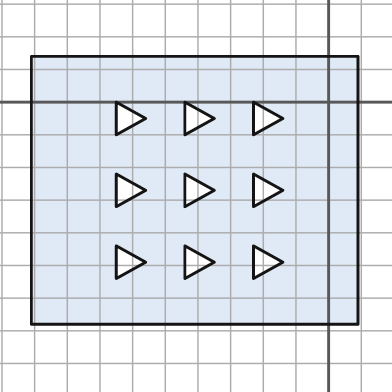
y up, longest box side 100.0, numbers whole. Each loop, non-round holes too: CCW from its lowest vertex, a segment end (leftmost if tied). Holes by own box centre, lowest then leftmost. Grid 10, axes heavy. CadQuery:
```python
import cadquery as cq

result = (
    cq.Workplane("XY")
    .moveTo(-91.0, -68.0)
    .lineTo(9.0, -68.0)
    .lineTo(9.0, 14.0)
    .lineTo(-91.0, 14.0)
    .close()
    .moveTo(-65.0, -54.0)
    .lineTo(-56.0, -49.0)
    .lineTo(-65.0, -44.0)
    .close()
    .moveTo(-44.0, -54.0)
    .lineTo(-35.0, -49.0)
    .lineTo(-44.0, -44.0)
    .close()
    .moveTo(-23.0, -54.0)
    .lineTo(-14.0, -49.0)
    .lineTo(-23.0, -44.0)
    .close()
    .moveTo(-65.0, -32.0)
    .lineTo(-56.0, -27.0)
    .lineTo(-65.0, -22.0)
    .close()
    .moveTo(-44.0, -32.0)
    .lineTo(-35.0, -27.0)
    .lineTo(-44.0, -22.0)
    .close()
    .moveTo(-23.0, -32.0)
    .lineTo(-14.0, -27.0)
    .lineTo(-23.0, -22.0)
    .close()
    .moveTo(-65.0, -10.0)
    .lineTo(-56.0, -5.0)
    .lineTo(-65.0, 0.0)
    .close()
    .moveTo(-44.0, -10.0)
    .lineTo(-35.0, -5.0)
    .lineTo(-44.0, 0.0)
    .close()
    .moveTo(-23.0, -10.0)
    .lineTo(-14.0, -5.0)
    .lineTo(-23.0, 0.0)
    .close()
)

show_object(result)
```